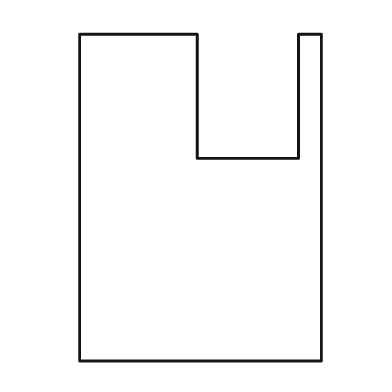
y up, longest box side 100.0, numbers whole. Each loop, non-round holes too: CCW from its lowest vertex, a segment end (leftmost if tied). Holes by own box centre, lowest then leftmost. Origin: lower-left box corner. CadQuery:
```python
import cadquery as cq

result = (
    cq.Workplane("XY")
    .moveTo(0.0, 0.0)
    .lineTo(74.0, 0.0)
    .lineTo(74.0, 100.0)
    .lineTo(67.0, 100.0)
    .lineTo(67.0, 62.0)
    .lineTo(36.0, 62.0)
    .lineTo(36.0, 100.0)
    .lineTo(0.0, 100.0)
    .close()
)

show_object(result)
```